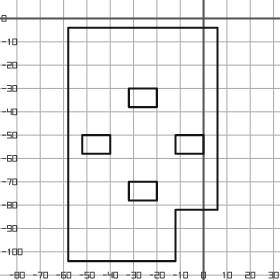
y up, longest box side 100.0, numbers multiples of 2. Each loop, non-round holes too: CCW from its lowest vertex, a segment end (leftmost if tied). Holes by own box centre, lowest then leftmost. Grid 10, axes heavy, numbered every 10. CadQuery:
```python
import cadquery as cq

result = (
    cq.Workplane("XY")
    .moveTo(-58.0, -104.0)
    .lineTo(-12.0, -104.0)
    .lineTo(-12.0, -82.0)
    .lineTo(6.0, -82.0)
    .lineTo(6.0, -4.0)
    .lineTo(-58.0, -4.0)
    .close()
    .moveTo(-32.0, -78.0)
    .lineTo(-20.0, -78.0)
    .lineTo(-20.0, -70.0)
    .lineTo(-32.0, -70.0)
    .close()
    .moveTo(-52.0, -58.0)
    .lineTo(-40.0, -58.0)
    .lineTo(-40.0, -50.0)
    .lineTo(-52.0, -50.0)
    .close()
    .moveTo(-12.0, -58.0)
    .lineTo(0.0, -58.0)
    .lineTo(0.0, -50.0)
    .lineTo(-12.0, -50.0)
    .close()
    .moveTo(-32.0, -38.0)
    .lineTo(-20.0, -38.0)
    .lineTo(-20.0, -30.0)
    .lineTo(-32.0, -30.0)
    .close()
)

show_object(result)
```